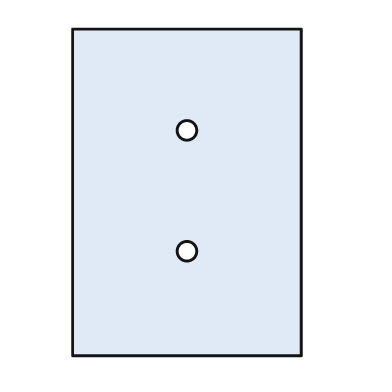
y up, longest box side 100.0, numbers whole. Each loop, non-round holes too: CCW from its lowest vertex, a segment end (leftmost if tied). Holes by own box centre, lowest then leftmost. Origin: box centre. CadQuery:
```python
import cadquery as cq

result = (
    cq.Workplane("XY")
    .moveTo(-35.0, -50.0)
    .lineTo(35.0, -50.0)
    .lineTo(35.0, 50.0)
    .lineTo(-35.0, 50.0)
    .close()
    .moveTo(0.0, -18.0)
    .circle(3.0)
    .moveTo(0.0, 19.0)
    .circle(3.0)
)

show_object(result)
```